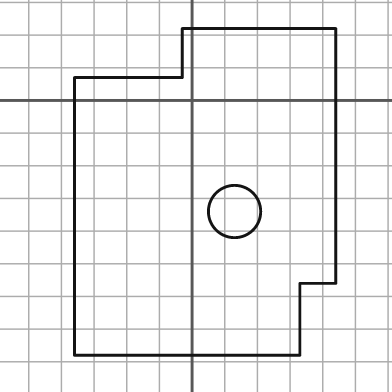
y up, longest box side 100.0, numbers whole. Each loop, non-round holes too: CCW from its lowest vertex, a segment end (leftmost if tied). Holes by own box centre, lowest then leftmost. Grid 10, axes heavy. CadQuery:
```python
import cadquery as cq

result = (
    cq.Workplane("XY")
    .moveTo(-36.0, -78.0)
    .lineTo(33.0, -78.0)
    .lineTo(33.0, -56.0)
    .lineTo(44.0, -56.0)
    .lineTo(44.0, 22.0)
    .lineTo(-3.0, 22.0)
    .lineTo(-3.0, 7.0)
    .lineTo(-36.0, 7.0)
    .close()
    .moveTo(13.0, -34.0)
    .circle(8.0)
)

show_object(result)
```